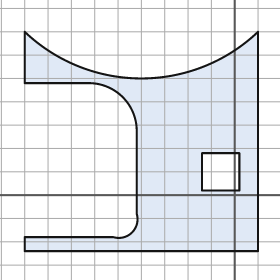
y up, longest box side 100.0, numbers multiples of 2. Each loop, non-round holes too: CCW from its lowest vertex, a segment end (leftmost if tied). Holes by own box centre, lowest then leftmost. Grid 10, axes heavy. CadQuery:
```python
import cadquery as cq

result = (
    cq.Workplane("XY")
    .moveTo(-90.0, -24.0)
    .lineTo(10.0, -24.0)
    .lineTo(10.0, 70.0)
    .threePointArc((-40.0, 50.0), (-90.0, 70.0))
    .lineTo(-90.0, 48.0)
    .lineTo(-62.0, 48.0)
    .threePointArc((-48.0, 42.0), (-42.0, 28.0))
    .lineTo(-42.0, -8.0)
    .threePointArc((-44.0, -16.0), (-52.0, -18.0))
    .lineTo(-90.0, -18.0)
    .close()
    .moveTo(-14.0, 2.0)
    .lineTo(2.0, 2.0)
    .lineTo(2.0, 18.0)
    .lineTo(-14.0, 18.0)
    .close()
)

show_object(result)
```